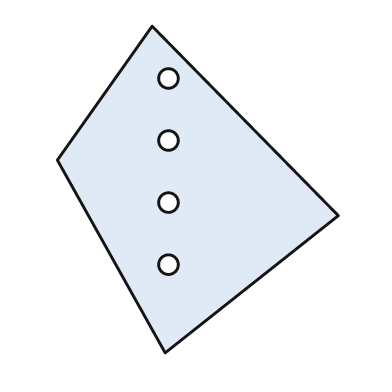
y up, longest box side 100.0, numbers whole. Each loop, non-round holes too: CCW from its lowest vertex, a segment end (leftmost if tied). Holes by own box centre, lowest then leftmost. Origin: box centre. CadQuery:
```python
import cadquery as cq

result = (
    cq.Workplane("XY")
    .moveTo(-10.0, -50.0)
    .lineTo(43.0, -8.0)
    .lineTo(-14.0, 50.0)
    .lineTo(-43.0, 9.0)
    .close()
    .moveTo(-9.0, -23.0)
    .circle(3.0)
    .moveTo(-9.0, -4.0)
    .circle(3.0)
    .moveTo(-9.0, 15.0)
    .circle(3.0)
    .moveTo(-9.0, 34.0)
    .circle(3.0)
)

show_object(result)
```